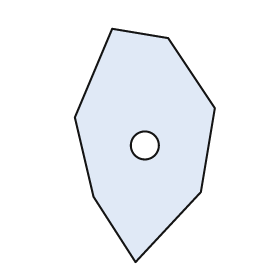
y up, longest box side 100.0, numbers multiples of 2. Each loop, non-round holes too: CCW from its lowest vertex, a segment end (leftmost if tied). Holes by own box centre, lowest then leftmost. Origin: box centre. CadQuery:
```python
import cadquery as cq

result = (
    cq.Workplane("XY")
    .moveTo(-4.0, -50.0)
    .lineTo(24.0, -20.0)
    .lineTo(30.0, 16.0)
    .lineTo(10.0, 46.0)
    .lineTo(-14.0, 50.0)
    .lineTo(-30.0, 12.0)
    .lineTo(-22.0, -22.0)
    .close()
    .moveTo(0.0, 0.0)
    .circle(6.0)
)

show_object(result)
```